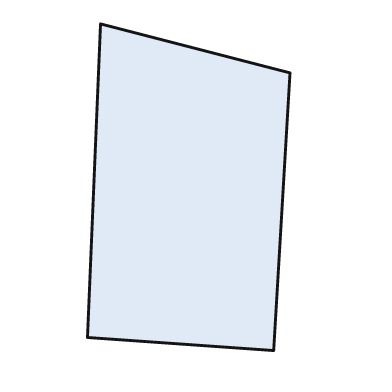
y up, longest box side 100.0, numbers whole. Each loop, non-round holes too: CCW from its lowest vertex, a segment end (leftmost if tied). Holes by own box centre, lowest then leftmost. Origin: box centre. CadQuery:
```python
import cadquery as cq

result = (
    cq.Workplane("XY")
    .moveTo(26.0, -50.0)
    .lineTo(31.0, 35.0)
    .lineTo(-27.0, 50.0)
    .lineTo(-31.0, -46.0)
    .close()
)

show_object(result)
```